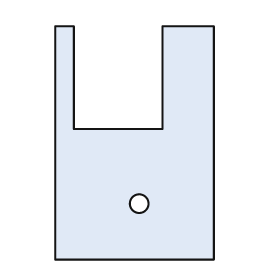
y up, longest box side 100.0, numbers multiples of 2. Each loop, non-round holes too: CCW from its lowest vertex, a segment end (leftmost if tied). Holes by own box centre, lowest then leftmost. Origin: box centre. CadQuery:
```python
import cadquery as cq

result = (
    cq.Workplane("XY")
    .moveTo(-34.0, -50.0)
    .lineTo(34.0, -50.0)
    .lineTo(34.0, 50.0)
    .lineTo(12.0, 50.0)
    .lineTo(12.0, 6.0)
    .lineTo(-26.0, 6.0)
    .lineTo(-26.0, 50.0)
    .lineTo(-34.0, 50.0)
    .close()
    .moveTo(2.0, -26.0)
    .circle(4.0)
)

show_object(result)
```